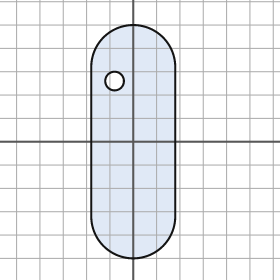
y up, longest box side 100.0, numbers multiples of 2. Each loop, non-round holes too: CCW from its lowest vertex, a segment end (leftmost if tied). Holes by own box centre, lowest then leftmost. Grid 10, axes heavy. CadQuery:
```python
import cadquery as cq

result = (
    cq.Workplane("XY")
    .moveTo(-18.0, -32.0)
    .threePointArc((0.0, -50.0), (18.0, -32.0))
    .lineTo(18.0, 32.0)
    .threePointArc((0.0, 50.0), (-18.0, 32.0))
    .close()
    .moveTo(-8.0, 26.0)
    .circle(4.0)
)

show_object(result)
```